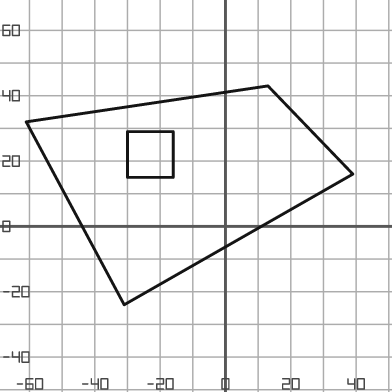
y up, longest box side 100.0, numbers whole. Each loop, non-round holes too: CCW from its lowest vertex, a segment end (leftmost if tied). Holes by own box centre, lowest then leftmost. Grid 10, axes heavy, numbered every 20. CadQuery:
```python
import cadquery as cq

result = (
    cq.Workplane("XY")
    .moveTo(-31.0, -24.0)
    .lineTo(39.0, 16.0)
    .lineTo(13.0, 43.0)
    .lineTo(-61.0, 32.0)
    .close()
    .moveTo(-30.0, 15.0)
    .lineTo(-16.0, 15.0)
    .lineTo(-16.0, 29.0)
    .lineTo(-30.0, 29.0)
    .close()
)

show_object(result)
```